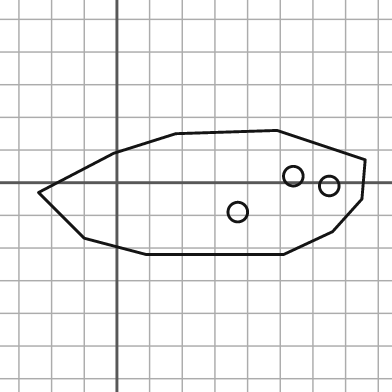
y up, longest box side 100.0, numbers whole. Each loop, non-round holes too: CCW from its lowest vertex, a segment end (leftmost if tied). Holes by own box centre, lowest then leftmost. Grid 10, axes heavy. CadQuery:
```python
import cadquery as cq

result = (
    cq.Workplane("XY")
    .moveTo(9.0, -22.0)
    .lineTo(51.0, -22.0)
    .lineTo(66.0, -15.0)
    .lineTo(75.0, -5.0)
    .lineTo(76.0, 7.0)
    .lineTo(49.0, 16.0)
    .lineTo(18.0, 15.0)
    .lineTo(-1.0, 9.0)
    .lineTo(-24.0, -3.0)
    .lineTo(-10.0, -17.0)
    .close()
    .moveTo(37.0, -9.0)
    .circle(3.0)
    .moveTo(65.0, -1.0)
    .circle(3.0)
    .moveTo(54.0, 2.0)
    .circle(3.0)
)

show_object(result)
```